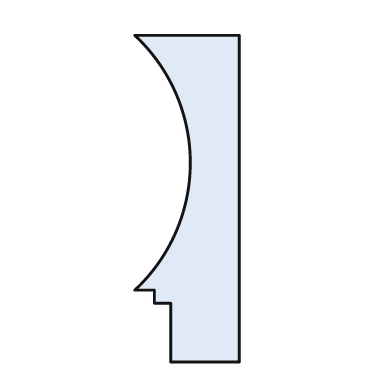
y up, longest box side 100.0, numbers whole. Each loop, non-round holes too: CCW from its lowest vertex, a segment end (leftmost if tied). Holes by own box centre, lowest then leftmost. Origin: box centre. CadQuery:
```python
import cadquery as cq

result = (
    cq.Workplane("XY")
    .moveTo(-5.0, -50.0)
    .lineTo(16.0, -50.0)
    .lineTo(16.0, 50.0)
    .lineTo(-16.0, 50.0)
    .threePointArc((1.0, 11.0), (-16.0, -28.0))
    .lineTo(-10.0, -28.0)
    .lineTo(-10.0, -32.0)
    .lineTo(-5.0, -32.0)
    .close()
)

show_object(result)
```